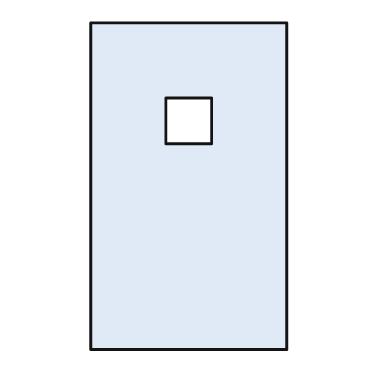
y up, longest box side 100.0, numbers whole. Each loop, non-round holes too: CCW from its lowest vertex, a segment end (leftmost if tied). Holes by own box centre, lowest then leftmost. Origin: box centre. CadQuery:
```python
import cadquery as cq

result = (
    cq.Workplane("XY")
    .moveTo(-30.0, -50.0)
    .lineTo(30.0, -50.0)
    .lineTo(30.0, 50.0)
    .lineTo(-30.0, 50.0)
    .close()
    .moveTo(-7.0, 13.0)
    .lineTo(7.0, 13.0)
    .lineTo(7.0, 27.0)
    .lineTo(-7.0, 27.0)
    .close()
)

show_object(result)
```